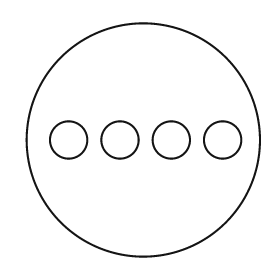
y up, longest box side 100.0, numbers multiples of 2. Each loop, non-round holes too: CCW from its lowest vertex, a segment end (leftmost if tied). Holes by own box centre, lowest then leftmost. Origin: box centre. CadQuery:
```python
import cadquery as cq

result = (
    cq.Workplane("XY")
    .moveTo(0.0, 0.0)
    .circle(50.0)
    .moveTo(-32.0, 0.0)
    .circle(8.0)
    .moveTo(-10.0, 0.0)
    .circle(8.0)
    .moveTo(12.0, 0.0)
    .circle(8.0)
    .moveTo(34.0, 0.0)
    .circle(8.0)
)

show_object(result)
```